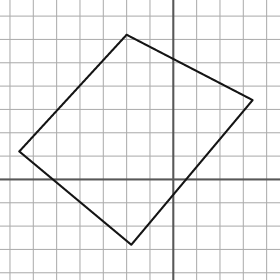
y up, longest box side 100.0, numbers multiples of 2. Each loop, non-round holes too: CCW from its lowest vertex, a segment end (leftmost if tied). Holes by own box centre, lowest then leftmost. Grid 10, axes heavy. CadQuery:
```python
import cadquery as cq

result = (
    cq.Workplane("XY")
    .moveTo(-18.0, -28.0)
    .lineTo(34.0, 34.0)
    .lineTo(-20.0, 62.0)
    .lineTo(-66.0, 12.0)
    .close()
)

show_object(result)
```